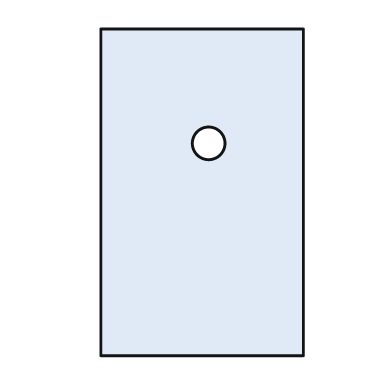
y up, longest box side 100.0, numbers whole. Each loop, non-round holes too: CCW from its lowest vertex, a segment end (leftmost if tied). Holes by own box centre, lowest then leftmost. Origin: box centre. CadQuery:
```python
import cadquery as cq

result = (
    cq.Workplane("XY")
    .moveTo(-31.0, -50.0)
    .lineTo(31.0, -50.0)
    .lineTo(31.0, 50.0)
    .lineTo(-31.0, 50.0)
    .close()
    .moveTo(2.0, 15.0)
    .circle(5.0)
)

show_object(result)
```